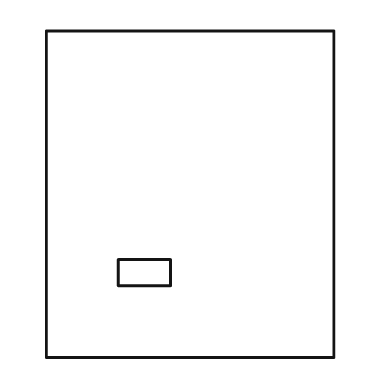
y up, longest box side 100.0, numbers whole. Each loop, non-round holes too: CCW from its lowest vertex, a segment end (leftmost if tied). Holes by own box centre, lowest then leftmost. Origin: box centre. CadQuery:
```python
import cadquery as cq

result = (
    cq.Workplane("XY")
    .moveTo(-44.0, -50.0)
    .lineTo(44.0, -50.0)
    .lineTo(44.0, 50.0)
    .lineTo(-44.0, 50.0)
    .close()
    .moveTo(-22.0, -28.0)
    .lineTo(-6.0, -28.0)
    .lineTo(-6.0, -20.0)
    .lineTo(-22.0, -20.0)
    .close()
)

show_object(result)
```